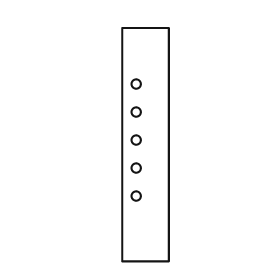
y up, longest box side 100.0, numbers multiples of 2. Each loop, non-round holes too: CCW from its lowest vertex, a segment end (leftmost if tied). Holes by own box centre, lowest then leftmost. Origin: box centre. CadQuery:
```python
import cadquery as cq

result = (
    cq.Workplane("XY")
    .moveTo(-10.0, -50.0)
    .lineTo(10.0, -50.0)
    .lineTo(10.0, 50.0)
    .lineTo(-10.0, 50.0)
    .close()
    .moveTo(-4.0, -22.0)
    .circle(2.0)
    .moveTo(-4.0, -10.0)
    .circle(2.0)
    .moveTo(-4.0, 2.0)
    .circle(2.0)
    .moveTo(-4.0, 14.0)
    .circle(2.0)
    .moveTo(-4.0, 26.0)
    .circle(2.0)
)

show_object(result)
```